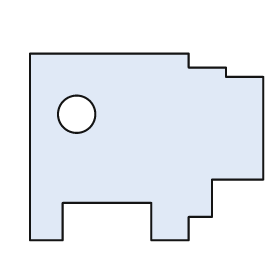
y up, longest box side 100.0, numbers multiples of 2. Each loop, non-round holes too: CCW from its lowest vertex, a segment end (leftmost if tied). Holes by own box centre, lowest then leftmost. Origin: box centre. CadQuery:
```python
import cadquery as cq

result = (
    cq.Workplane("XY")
    .moveTo(-50.0, -40.0)
    .lineTo(-36.0, -40.0)
    .lineTo(-36.0, -24.0)
    .lineTo(2.0, -24.0)
    .lineTo(2.0, -40.0)
    .lineTo(18.0, -40.0)
    .lineTo(18.0, -30.0)
    .lineTo(28.0, -30.0)
    .lineTo(28.0, -14.0)
    .lineTo(50.0, -14.0)
    .lineTo(50.0, 30.0)
    .lineTo(34.0, 30.0)
    .lineTo(34.0, 34.0)
    .lineTo(18.0, 34.0)
    .lineTo(18.0, 40.0)
    .lineTo(-50.0, 40.0)
    .close()
    .moveTo(-30.0, 14.0)
    .circle(8.0)
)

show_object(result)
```